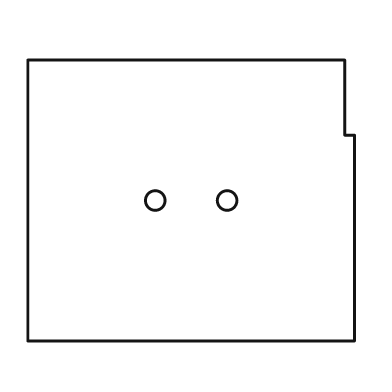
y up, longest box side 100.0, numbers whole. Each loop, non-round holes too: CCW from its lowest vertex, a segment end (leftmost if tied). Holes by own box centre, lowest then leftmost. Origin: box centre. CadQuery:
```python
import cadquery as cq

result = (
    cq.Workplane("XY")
    .moveTo(-50.0, -43.0)
    .lineTo(50.0, -43.0)
    .lineTo(50.0, 20.0)
    .lineTo(47.0, 20.0)
    .lineTo(47.0, 43.0)
    .lineTo(-50.0, 43.0)
    .close()
    .moveTo(-11.0, 0.0)
    .circle(3.0)
    .moveTo(11.0, 0.0)
    .circle(3.0)
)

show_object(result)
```